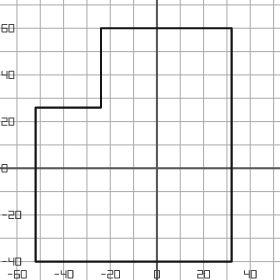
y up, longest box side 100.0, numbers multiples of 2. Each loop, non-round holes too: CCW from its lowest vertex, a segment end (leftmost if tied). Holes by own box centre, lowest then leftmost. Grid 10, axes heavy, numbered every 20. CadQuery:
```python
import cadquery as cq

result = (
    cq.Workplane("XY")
    .moveTo(-52.0, -40.0)
    .lineTo(32.0, -40.0)
    .lineTo(32.0, 60.0)
    .lineTo(-24.0, 60.0)
    .lineTo(-24.0, 26.0)
    .lineTo(-52.0, 26.0)
    .close()
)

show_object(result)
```